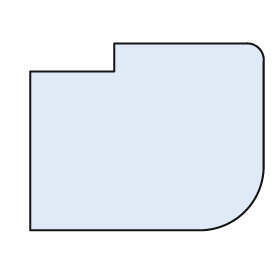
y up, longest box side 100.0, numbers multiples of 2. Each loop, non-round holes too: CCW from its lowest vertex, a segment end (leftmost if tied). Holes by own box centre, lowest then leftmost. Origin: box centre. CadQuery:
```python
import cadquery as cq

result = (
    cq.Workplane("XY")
    .moveTo(-50.0, -40.0)
    .lineTo(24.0, -40.0)
    .threePointArc((42.0, -32.0), (50.0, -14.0))
    .lineTo(50.0, 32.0)
    .threePointArc((48.0, 38.0), (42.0, 40.0))
    .lineTo(-14.0, 40.0)
    .lineTo(-14.0, 28.0)
    .lineTo(-50.0, 28.0)
    .close()
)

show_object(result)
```